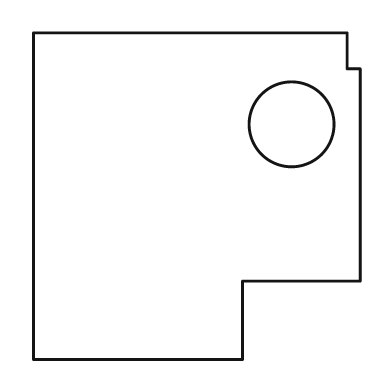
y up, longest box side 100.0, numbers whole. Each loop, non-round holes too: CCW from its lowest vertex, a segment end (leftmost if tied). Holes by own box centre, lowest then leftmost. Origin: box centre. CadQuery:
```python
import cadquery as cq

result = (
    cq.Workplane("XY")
    .moveTo(-50.0, -50.0)
    .lineTo(14.0, -50.0)
    .lineTo(14.0, -26.0)
    .lineTo(50.0, -26.0)
    .lineTo(50.0, 39.0)
    .lineTo(46.0, 39.0)
    .lineTo(46.0, 50.0)
    .lineTo(-50.0, 50.0)
    .close()
    .moveTo(29.0, 22.0)
    .circle(13.0)
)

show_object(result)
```